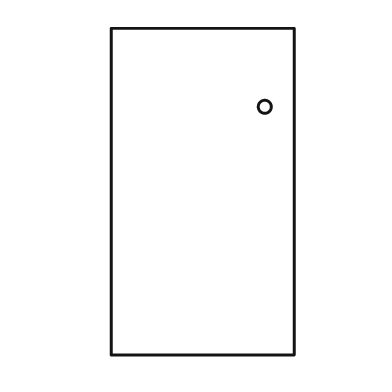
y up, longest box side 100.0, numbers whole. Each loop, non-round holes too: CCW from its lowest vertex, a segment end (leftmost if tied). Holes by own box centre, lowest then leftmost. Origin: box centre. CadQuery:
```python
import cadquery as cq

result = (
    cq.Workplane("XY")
    .moveTo(-28.0, -50.0)
    .lineTo(28.0, -50.0)
    .lineTo(28.0, 50.0)
    .lineTo(-28.0, 50.0)
    .close()
    .moveTo(19.0, 26.0)
    .circle(2.0)
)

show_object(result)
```